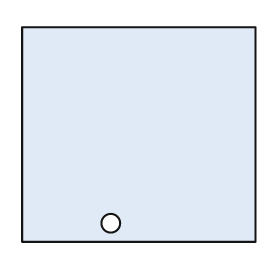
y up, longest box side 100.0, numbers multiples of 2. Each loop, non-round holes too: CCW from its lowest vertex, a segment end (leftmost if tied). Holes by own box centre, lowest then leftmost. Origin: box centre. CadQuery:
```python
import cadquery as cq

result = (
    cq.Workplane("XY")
    .moveTo(-50.0, -46.0)
    .lineTo(50.0, -46.0)
    .lineTo(50.0, 46.0)
    .lineTo(-50.0, 46.0)
    .close()
    .moveTo(-12.0, -38.0)
    .circle(4.0)
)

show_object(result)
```